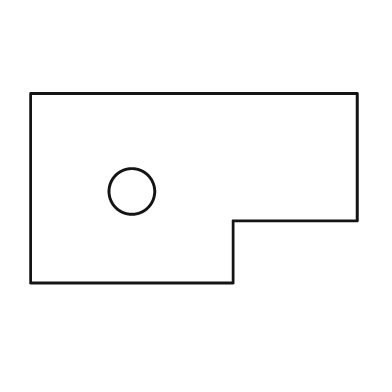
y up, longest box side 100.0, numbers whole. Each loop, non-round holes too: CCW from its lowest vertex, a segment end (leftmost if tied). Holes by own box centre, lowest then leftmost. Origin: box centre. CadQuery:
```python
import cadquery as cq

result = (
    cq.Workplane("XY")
    .moveTo(-50.0, -29.0)
    .lineTo(12.0, -29.0)
    .lineTo(12.0, -10.0)
    .lineTo(50.0, -10.0)
    .lineTo(50.0, 29.0)
    .lineTo(-50.0, 29.0)
    .close()
    .moveTo(-19.0, -1.0)
    .circle(7.0)
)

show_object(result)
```